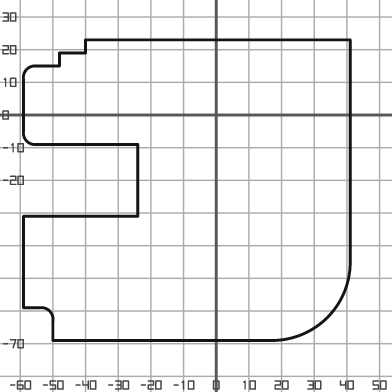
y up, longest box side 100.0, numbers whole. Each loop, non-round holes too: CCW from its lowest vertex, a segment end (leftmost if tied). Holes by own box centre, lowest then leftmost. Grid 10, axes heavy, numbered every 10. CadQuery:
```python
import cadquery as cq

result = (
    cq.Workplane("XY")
    .moveTo(-50.0, -69.0)
    .lineTo(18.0, -69.0)
    .threePointArc((34.0, -62.0), (41.0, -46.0))
    .lineTo(41.0, 23.0)
    .lineTo(-40.0, 23.0)
    .lineTo(-40.0, 19.0)
    .lineTo(-48.0, 19.0)
    .lineTo(-48.0, 15.0)
    .lineTo(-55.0, 15.0)
    .threePointArc((-58.0, 14.0), (-59.0, 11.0))
    .lineTo(-59.0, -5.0)
    .threePointArc((-58.0, -8.0), (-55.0, -9.0))
    .lineTo(-24.0, -9.0)
    .lineTo(-24.0, -31.0)
    .lineTo(-59.0, -31.0)
    .lineTo(-59.0, -59.0)
    .lineTo(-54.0, -59.0)
    .threePointArc((-51.0, -60.0), (-50.0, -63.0))
    .close()
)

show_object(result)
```